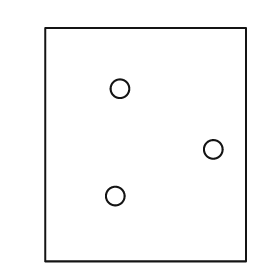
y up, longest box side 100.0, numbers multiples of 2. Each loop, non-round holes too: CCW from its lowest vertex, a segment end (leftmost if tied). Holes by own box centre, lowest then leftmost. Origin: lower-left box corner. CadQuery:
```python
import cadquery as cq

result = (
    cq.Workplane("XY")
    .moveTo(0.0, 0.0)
    .lineTo(86.0, 0.0)
    .lineTo(86.0, 100.0)
    .lineTo(0.0, 100.0)
    .close()
    .moveTo(30.0, 28.0)
    .circle(4.0)
    .moveTo(72.0, 48.0)
    .circle(4.0)
    .moveTo(32.0, 74.0)
    .circle(4.0)
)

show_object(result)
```